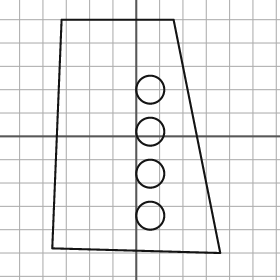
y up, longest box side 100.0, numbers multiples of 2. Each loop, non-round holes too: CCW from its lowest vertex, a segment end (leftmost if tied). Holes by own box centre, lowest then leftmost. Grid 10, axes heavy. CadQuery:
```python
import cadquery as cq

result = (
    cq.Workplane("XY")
    .moveTo(36.0, -50.0)
    .lineTo(16.0, 50.0)
    .lineTo(-32.0, 50.0)
    .lineTo(-36.0, -48.0)
    .close()
    .moveTo(6.0, -34.0)
    .circle(6.0)
    .moveTo(6.0, -16.0)
    .circle(6.0)
    .moveTo(6.0, 2.0)
    .circle(6.0)
    .moveTo(6.0, 20.0)
    .circle(6.0)
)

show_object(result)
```